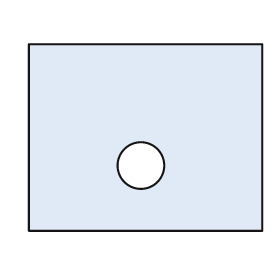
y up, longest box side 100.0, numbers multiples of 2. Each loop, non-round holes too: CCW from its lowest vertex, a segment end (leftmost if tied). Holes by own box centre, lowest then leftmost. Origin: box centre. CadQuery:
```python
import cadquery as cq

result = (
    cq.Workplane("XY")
    .moveTo(-50.0, -40.0)
    .lineTo(50.0, -40.0)
    .lineTo(50.0, 40.0)
    .lineTo(-50.0, 40.0)
    .close()
    .moveTo(-2.0, -12.0)
    .circle(10.0)
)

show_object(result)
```